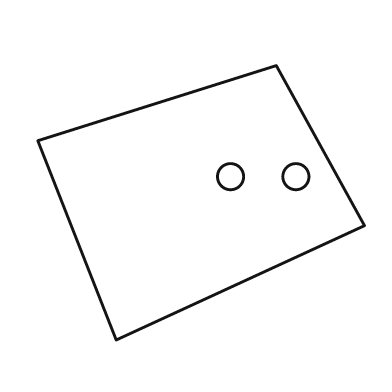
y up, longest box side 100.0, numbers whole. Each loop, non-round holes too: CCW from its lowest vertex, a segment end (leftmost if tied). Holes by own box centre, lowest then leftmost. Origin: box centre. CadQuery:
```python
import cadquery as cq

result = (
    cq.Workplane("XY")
    .moveTo(-26.0, -42.0)
    .lineTo(50.0, -7.0)
    .lineTo(23.0, 42.0)
    .lineTo(-50.0, 19.0)
    .close()
    .moveTo(9.0, 8.0)
    .circle(4.0)
    .moveTo(29.0, 8.0)
    .circle(4.0)
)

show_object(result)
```